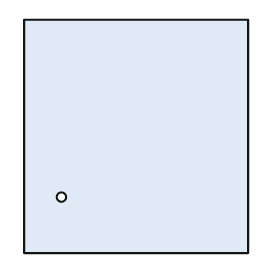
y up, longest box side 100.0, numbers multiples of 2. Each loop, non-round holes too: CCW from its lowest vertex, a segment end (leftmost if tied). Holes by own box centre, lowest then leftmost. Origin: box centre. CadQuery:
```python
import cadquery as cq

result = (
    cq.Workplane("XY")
    .moveTo(-48.0, -50.0)
    .lineTo(48.0, -50.0)
    .lineTo(48.0, 50.0)
    .lineTo(-48.0, 50.0)
    .close()
    .moveTo(-32.0, -26.0)
    .circle(2.0)
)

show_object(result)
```